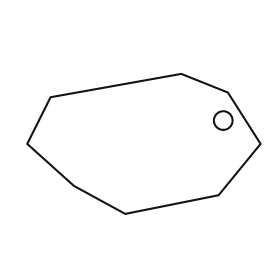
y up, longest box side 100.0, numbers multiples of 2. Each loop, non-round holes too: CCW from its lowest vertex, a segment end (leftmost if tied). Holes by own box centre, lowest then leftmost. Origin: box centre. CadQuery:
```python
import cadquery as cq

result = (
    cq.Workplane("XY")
    .moveTo(-8.0, -30.0)
    .lineTo(32.0, -22.0)
    .lineTo(50.0, 0.0)
    .lineTo(36.0, 22.0)
    .lineTo(16.0, 30.0)
    .lineTo(-40.0, 20.0)
    .lineTo(-50.0, 0.0)
    .lineTo(-30.0, -18.0)
    .close()
    .moveTo(34.0, 10.0)
    .circle(4.0)
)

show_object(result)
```